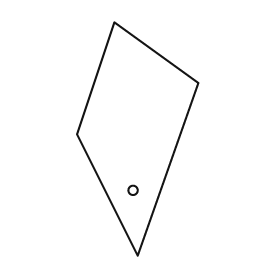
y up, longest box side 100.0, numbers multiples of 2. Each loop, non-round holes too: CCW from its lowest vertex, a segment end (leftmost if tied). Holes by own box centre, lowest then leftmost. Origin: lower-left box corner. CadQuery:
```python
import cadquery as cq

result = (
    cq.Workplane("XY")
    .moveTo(26.0, 0.0)
    .lineTo(52.0, 74.0)
    .lineTo(16.0, 100.0)
    .lineTo(0.0, 52.0)
    .close()
    .moveTo(24.0, 28.0)
    .circle(2.0)
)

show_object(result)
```